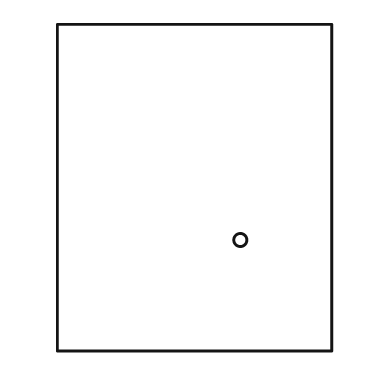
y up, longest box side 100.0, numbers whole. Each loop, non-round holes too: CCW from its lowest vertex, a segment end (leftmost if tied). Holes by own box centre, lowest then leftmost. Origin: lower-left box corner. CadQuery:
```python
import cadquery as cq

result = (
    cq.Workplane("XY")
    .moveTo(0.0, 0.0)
    .lineTo(84.0, 0.0)
    .lineTo(84.0, 100.0)
    .lineTo(0.0, 100.0)
    .close()
    .moveTo(56.0, 34.0)
    .circle(2.0)
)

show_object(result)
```